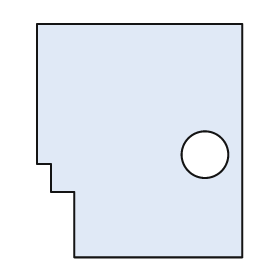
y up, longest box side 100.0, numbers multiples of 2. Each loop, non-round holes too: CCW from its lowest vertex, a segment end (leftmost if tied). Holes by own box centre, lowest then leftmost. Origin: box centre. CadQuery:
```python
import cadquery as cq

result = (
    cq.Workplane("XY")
    .moveTo(-28.0, -50.0)
    .lineTo(44.0, -50.0)
    .lineTo(44.0, 50.0)
    .lineTo(-44.0, 50.0)
    .lineTo(-44.0, -10.0)
    .lineTo(-38.0, -10.0)
    .lineTo(-38.0, -22.0)
    .lineTo(-28.0, -22.0)
    .close()
    .moveTo(28.0, -6.0)
    .circle(10.0)
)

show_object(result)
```